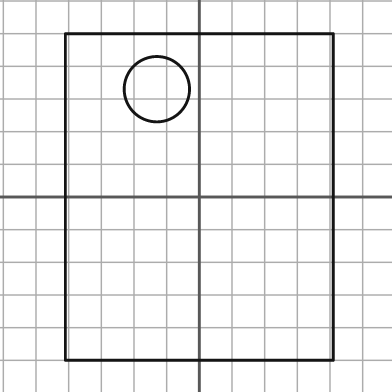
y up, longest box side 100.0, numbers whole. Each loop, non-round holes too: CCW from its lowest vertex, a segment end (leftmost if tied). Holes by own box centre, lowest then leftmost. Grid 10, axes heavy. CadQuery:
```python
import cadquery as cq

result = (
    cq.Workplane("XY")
    .moveTo(-41.0, -50.0)
    .lineTo(41.0, -50.0)
    .lineTo(41.0, 50.0)
    .lineTo(-41.0, 50.0)
    .close()
    .moveTo(-13.0, 33.0)
    .circle(10.0)
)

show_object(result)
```